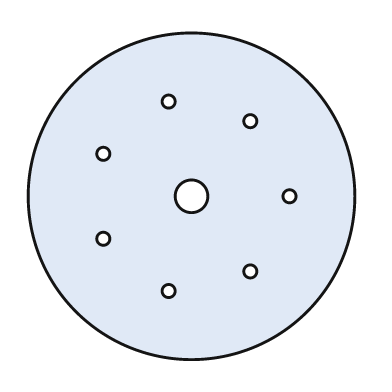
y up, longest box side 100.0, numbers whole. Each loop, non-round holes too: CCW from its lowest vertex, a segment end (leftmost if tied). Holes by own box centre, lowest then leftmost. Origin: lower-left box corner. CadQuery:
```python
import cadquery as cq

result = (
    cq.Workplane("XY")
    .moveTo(50.0, 50.0)
    .circle(50.0)
    .moveTo(43.0, 21.0)
    .circle(2.0)
    .moveTo(68.0, 27.0)
    .circle(2.0)
    .moveTo(23.0, 37.0)
    .circle(2.0)
    .moveTo(50.0, 50.0)
    .circle(5.0)
    .moveTo(80.0, 50.0)
    .circle(2.0)
    .moveTo(23.0, 63.0)
    .circle(2.0)
    .moveTo(68.0, 73.0)
    .circle(2.0)
    .moveTo(43.0, 79.0)
    .circle(2.0)
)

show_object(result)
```